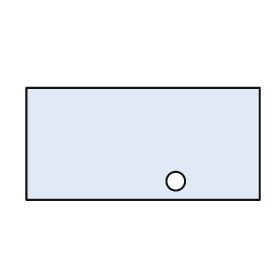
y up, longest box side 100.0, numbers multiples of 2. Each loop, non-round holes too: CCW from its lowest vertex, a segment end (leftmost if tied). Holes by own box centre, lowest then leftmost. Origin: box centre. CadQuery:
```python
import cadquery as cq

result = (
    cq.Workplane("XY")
    .moveTo(-50.0, -24.0)
    .lineTo(50.0, -24.0)
    .lineTo(50.0, 24.0)
    .lineTo(-50.0, 24.0)
    .close()
    .moveTo(14.0, -16.0)
    .circle(4.0)
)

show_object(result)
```